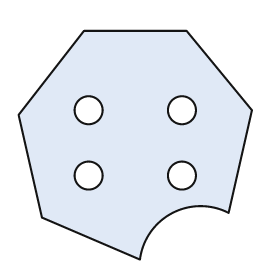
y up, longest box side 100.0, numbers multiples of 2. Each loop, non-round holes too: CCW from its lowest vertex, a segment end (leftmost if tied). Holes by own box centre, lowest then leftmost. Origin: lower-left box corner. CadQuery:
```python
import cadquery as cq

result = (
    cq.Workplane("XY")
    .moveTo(52.0, 0.0)
    .threePointArc((66.0, 20.0), (90.0, 20.0))
    .lineTo(100.0, 64.0)
    .lineTo(72.0, 98.0)
    .lineTo(28.0, 98.0)
    .lineTo(0.0, 62.0)
    .lineTo(10.0, 18.0)
    .close()
    .moveTo(30.0, 36.0)
    .circle(6.0)
    .moveTo(70.0, 36.0)
    .circle(6.0)
    .moveTo(30.0, 64.0)
    .circle(6.0)
    .moveTo(70.0, 64.0)
    .circle(6.0)
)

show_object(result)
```